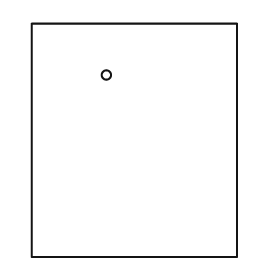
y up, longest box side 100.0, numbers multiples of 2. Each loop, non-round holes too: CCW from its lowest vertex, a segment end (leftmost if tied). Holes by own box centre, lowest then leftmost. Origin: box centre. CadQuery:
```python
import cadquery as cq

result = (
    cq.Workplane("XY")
    .moveTo(-44.0, -50.0)
    .lineTo(44.0, -50.0)
    .lineTo(44.0, 50.0)
    .lineTo(-44.0, 50.0)
    .close()
    .moveTo(-12.0, 28.0)
    .circle(2.0)
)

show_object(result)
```